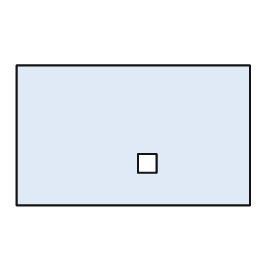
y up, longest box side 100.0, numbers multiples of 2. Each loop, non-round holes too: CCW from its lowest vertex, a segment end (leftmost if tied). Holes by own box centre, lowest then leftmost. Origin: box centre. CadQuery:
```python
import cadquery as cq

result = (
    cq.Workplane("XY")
    .moveTo(-50.0, -30.0)
    .lineTo(50.0, -30.0)
    .lineTo(50.0, 30.0)
    .lineTo(-50.0, 30.0)
    .close()
    .moveTo(2.0, -16.0)
    .lineTo(10.0, -16.0)
    .lineTo(10.0, -8.0)
    .lineTo(2.0, -8.0)
    .close()
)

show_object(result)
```